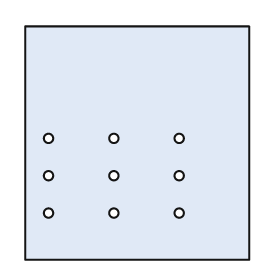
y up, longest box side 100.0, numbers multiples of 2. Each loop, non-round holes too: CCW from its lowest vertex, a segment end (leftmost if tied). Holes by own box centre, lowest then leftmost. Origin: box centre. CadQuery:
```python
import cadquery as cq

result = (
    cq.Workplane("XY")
    .moveTo(-48.0, -50.0)
    .lineTo(48.0, -50.0)
    .lineTo(48.0, 50.0)
    .lineTo(-48.0, 50.0)
    .close()
    .moveTo(-38.0, -30.0)
    .circle(2.0)
    .moveTo(-10.0, -30.0)
    .circle(2.0)
    .moveTo(18.0, -30.0)
    .circle(2.0)
    .moveTo(-38.0, -14.0)
    .circle(2.0)
    .moveTo(-10.0, -14.0)
    .circle(2.0)
    .moveTo(18.0, -14.0)
    .circle(2.0)
    .moveTo(-38.0, 2.0)
    .circle(2.0)
    .moveTo(-10.0, 2.0)
    .circle(2.0)
    .moveTo(18.0, 2.0)
    .circle(2.0)
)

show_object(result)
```